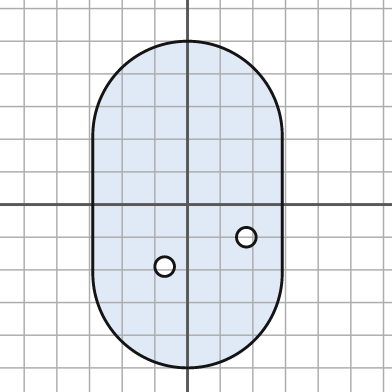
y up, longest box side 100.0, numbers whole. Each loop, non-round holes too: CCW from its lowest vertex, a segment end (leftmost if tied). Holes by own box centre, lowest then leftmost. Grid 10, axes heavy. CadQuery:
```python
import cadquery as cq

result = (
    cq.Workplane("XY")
    .moveTo(-29.0, -21.0)
    .threePointArc((0.0, -50.0), (29.0, -21.0))
    .lineTo(29.0, 21.0)
    .threePointArc((0.0, 50.0), (-29.0, 21.0))
    .close()
    .moveTo(-7.0, -19.0)
    .circle(3.0)
    .moveTo(18.0, -10.0)
    .circle(3.0)
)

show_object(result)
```